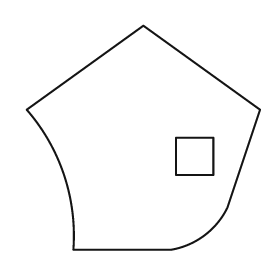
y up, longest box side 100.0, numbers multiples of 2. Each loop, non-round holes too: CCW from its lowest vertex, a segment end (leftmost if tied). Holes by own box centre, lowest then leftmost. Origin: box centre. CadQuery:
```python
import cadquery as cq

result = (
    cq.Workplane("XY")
    .moveTo(-30.0, -48.0)
    .lineTo(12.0, -48.0)
    .threePointArc((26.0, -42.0), (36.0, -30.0))
    .lineTo(50.0, 12.0)
    .lineTo(0.0, 48.0)
    .lineTo(-50.0, 12.0)
    .threePointArc((-34.0, -16.0), (-30.0, -48.0))
    .close()
    .moveTo(14.0, -16.0)
    .lineTo(30.0, -16.0)
    .lineTo(30.0, 0.0)
    .lineTo(14.0, 0.0)
    .close()
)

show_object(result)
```